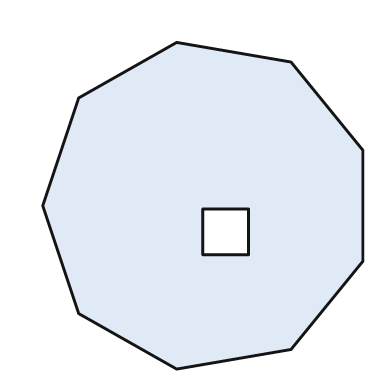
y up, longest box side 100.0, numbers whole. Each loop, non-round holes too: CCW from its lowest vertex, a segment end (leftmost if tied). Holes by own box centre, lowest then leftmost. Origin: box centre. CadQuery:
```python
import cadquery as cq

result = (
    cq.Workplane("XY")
    .moveTo(-8.0, -50.0)
    .lineTo(27.0, -44.0)
    .lineTo(49.0, -17.0)
    .lineTo(49.0, 17.0)
    .lineTo(27.0, 44.0)
    .lineTo(-8.0, 50.0)
    .lineTo(-38.0, 33.0)
    .lineTo(-49.0, 0.0)
    .lineTo(-38.0, -33.0)
    .close()
    .moveTo(0.0, -15.0)
    .lineTo(14.0, -15.0)
    .lineTo(14.0, -1.0)
    .lineTo(0.0, -1.0)
    .close()
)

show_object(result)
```